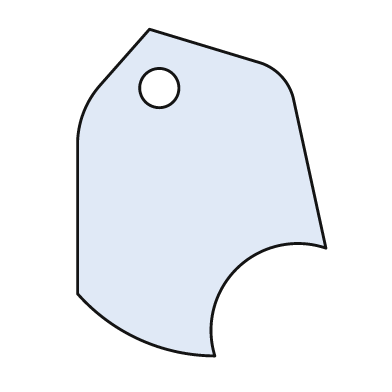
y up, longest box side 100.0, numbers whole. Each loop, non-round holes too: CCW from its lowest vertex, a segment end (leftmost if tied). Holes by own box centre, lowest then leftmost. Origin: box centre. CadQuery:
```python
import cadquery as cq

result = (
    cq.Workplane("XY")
    .moveTo(4.0, -50.0)
    .threePointArc((11.0, -23.0), (38.0, -17.0))
    .lineTo(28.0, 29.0)
    .threePointArc((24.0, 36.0), (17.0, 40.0))
    .lineTo(-16.0, 50.0)
    .lineTo(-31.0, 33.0)
    .threePointArc((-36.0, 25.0), (-38.0, 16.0))
    .lineTo(-38.0, -31.0)
    .threePointArc((-19.0, -45.0), (4.0, -50.0))
    .close()
    .moveTo(-13.0, 32.0)
    .circle(6.0)
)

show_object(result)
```